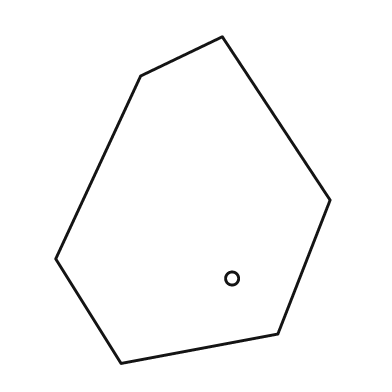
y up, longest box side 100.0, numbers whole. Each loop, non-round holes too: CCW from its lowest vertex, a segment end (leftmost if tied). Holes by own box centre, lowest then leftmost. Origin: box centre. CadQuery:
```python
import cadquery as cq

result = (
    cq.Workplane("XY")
    .moveTo(-22.0, -50.0)
    .lineTo(26.0, -41.0)
    .lineTo(42.0, 0.0)
    .lineTo(9.0, 50.0)
    .lineTo(-16.0, 38.0)
    .lineTo(-42.0, -18.0)
    .close()
    .moveTo(12.0, -24.0)
    .circle(2.0)
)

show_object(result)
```